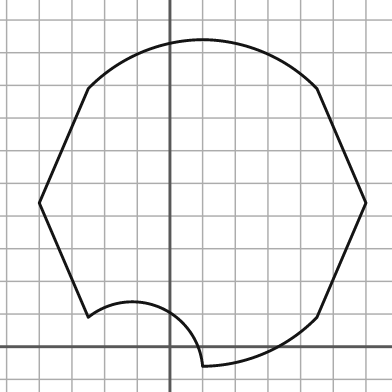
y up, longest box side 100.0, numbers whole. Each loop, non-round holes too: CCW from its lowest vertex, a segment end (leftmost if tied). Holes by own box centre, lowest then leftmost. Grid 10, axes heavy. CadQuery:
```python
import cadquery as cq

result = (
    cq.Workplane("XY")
    .moveTo(10.0, -6.0)
    .threePointArc((29.0, -2.0), (45.0, 9.0))
    .lineTo(60.0, 44.0)
    .lineTo(45.0, 79.0)
    .threePointArc((29.0, 90.0), (10.0, 94.0))
    .threePointArc((-9.0, 90.0), (-25.0, 79.0))
    .lineTo(-40.0, 44.0)
    .lineTo(-25.0, 9.0)
    .threePointArc((-3.0, 12.0), (10.0, -6.0))
    .close()
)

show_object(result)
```